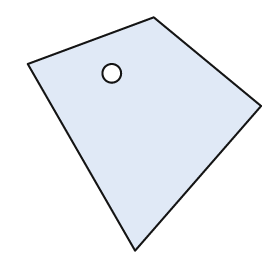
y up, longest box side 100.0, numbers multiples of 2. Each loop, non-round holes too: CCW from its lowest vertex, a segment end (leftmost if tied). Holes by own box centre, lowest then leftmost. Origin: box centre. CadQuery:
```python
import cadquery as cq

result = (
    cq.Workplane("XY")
    .moveTo(-4.0, -50.0)
    .lineTo(50.0, 12.0)
    .lineTo(4.0, 50.0)
    .lineTo(-50.0, 30.0)
    .close()
    .moveTo(-14.0, 26.0)
    .circle(4.0)
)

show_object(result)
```